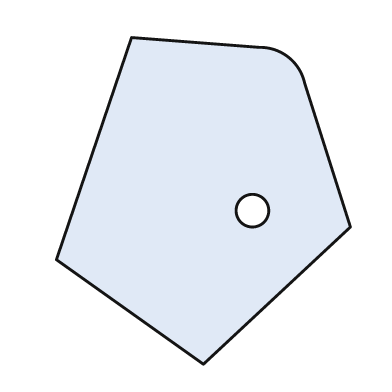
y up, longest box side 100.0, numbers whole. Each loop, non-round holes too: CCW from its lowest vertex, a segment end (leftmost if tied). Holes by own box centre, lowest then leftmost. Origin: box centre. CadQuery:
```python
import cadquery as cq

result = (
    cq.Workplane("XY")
    .moveTo(0.0, -50.0)
    .lineTo(45.0, -8.0)
    .lineTo(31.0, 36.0)
    .threePointArc((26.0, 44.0), (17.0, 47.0))
    .lineTo(-22.0, 50.0)
    .lineTo(-45.0, -18.0)
    .close()
    .moveTo(15.0, -3.0)
    .circle(5.0)
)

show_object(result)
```